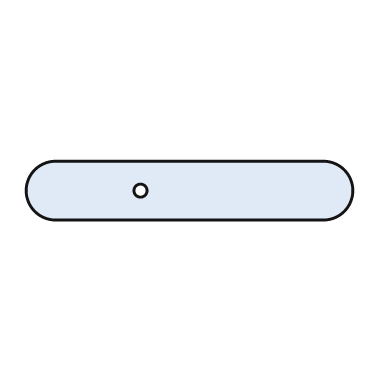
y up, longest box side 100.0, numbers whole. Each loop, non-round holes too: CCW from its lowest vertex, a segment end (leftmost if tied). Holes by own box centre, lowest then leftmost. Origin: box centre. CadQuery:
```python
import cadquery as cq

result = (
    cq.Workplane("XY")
    .moveTo(-41.0, -9.0)
    .lineTo(41.0, -9.0)
    .threePointArc((50.0, 0.0), (41.0, 9.0))
    .lineTo(-41.0, 9.0)
    .threePointArc((-50.0, 0.0), (-41.0, -9.0))
    .close()
    .moveTo(-15.0, 0.0)
    .circle(2.0)
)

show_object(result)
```